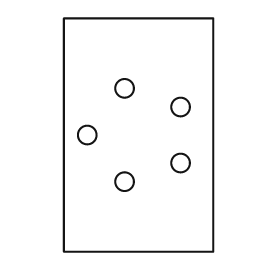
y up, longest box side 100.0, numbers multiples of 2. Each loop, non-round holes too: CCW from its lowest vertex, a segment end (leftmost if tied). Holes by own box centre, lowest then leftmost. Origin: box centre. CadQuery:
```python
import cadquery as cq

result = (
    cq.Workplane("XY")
    .moveTo(-32.0, -50.0)
    .lineTo(32.0, -50.0)
    .lineTo(32.0, 50.0)
    .lineTo(-32.0, 50.0)
    .close()
    .moveTo(-6.0, -20.0)
    .circle(4.0)
    .moveTo(18.0, -12.0)
    .circle(4.0)
    .moveTo(-22.0, 0.0)
    .circle(4.0)
    .moveTo(18.0, 12.0)
    .circle(4.0)
    .moveTo(-6.0, 20.0)
    .circle(4.0)
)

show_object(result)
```